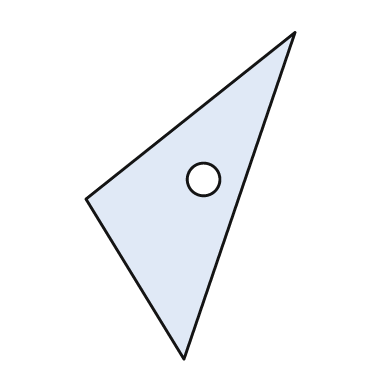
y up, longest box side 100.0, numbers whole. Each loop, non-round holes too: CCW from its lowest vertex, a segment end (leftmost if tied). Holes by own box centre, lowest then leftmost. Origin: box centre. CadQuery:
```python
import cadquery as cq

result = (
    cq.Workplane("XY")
    .moveTo(-2.0, -50.0)
    .lineTo(32.0, 50.0)
    .lineTo(-32.0, -1.0)
    .close()
    .moveTo(4.0, 5.0)
    .circle(5.0)
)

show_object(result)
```